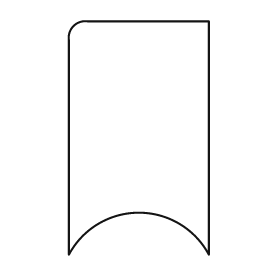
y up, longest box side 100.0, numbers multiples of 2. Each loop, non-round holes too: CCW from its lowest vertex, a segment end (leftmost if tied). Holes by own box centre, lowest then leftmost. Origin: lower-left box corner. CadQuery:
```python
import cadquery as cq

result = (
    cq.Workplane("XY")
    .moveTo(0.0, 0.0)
    .threePointArc((30.0, 18.0), (60.0, 0.0))
    .lineTo(60.0, 100.0)
    .lineTo(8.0, 100.0)
    .threePointArc((2.0, 98.0), (0.0, 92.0))
    .close()
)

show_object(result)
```